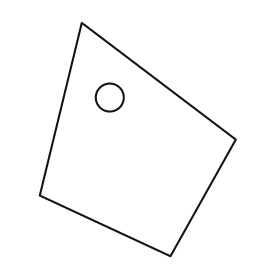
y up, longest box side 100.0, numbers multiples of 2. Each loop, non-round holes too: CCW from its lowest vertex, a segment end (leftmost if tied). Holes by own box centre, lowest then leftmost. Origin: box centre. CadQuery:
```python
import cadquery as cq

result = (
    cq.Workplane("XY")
    .moveTo(14.0, -50.0)
    .lineTo(42.0, 0.0)
    .lineTo(-24.0, 50.0)
    .lineTo(-42.0, -24.0)
    .close()
    .moveTo(-12.0, 18.0)
    .circle(6.0)
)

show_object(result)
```